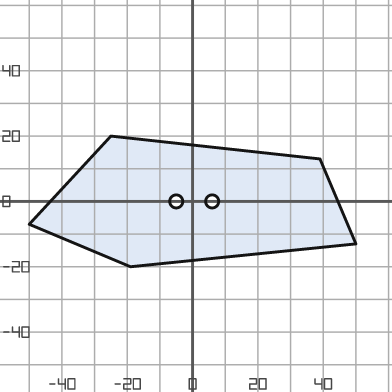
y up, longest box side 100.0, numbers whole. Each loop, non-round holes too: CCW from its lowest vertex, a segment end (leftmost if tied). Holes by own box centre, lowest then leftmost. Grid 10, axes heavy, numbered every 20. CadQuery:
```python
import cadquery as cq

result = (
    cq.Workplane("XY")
    .moveTo(-19.0, -20.0)
    .lineTo(50.0, -13.0)
    .lineTo(39.0, 13.0)
    .lineTo(-25.0, 20.0)
    .lineTo(-50.0, -7.0)
    .close()
    .moveTo(-5.0, 0.0)
    .circle(2.0)
    .moveTo(6.0, 0.0)
    .circle(2.0)
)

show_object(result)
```